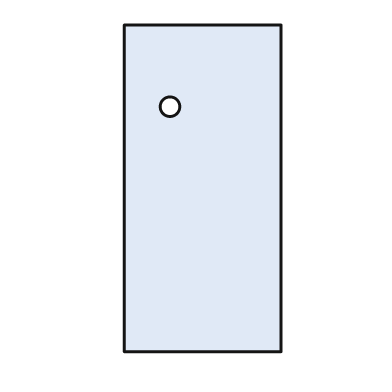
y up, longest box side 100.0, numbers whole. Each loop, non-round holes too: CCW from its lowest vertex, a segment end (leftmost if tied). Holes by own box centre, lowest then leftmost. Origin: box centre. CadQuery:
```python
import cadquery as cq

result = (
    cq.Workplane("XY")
    .moveTo(-24.0, -50.0)
    .lineTo(24.0, -50.0)
    .lineTo(24.0, 50.0)
    .lineTo(-24.0, 50.0)
    .close()
    .moveTo(-10.0, 25.0)
    .circle(3.0)
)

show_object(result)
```